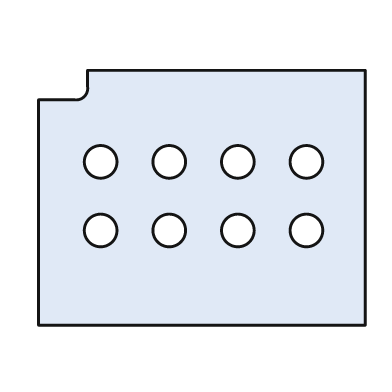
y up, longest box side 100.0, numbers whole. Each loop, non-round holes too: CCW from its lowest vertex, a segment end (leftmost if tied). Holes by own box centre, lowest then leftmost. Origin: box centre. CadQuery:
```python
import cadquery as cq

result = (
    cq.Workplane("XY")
    .moveTo(-50.0, -39.0)
    .lineTo(50.0, -39.0)
    .lineTo(50.0, 39.0)
    .lineTo(-35.0, 39.0)
    .lineTo(-35.0, 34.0)
    .threePointArc((-36.0, 31.0), (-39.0, 30.0))
    .lineTo(-50.0, 30.0)
    .close()
    .moveTo(-31.0, -10.0)
    .circle(5.0)
    .moveTo(-10.0, -10.0)
    .circle(5.0)
    .moveTo(11.0, -10.0)
    .circle(5.0)
    .moveTo(32.0, -10.0)
    .circle(5.0)
    .moveTo(-31.0, 11.0)
    .circle(5.0)
    .moveTo(-10.0, 11.0)
    .circle(5.0)
    .moveTo(11.0, 11.0)
    .circle(5.0)
    .moveTo(32.0, 11.0)
    .circle(5.0)
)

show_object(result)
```